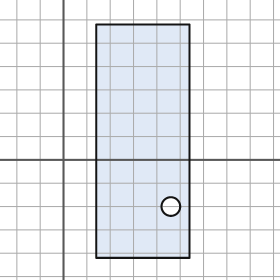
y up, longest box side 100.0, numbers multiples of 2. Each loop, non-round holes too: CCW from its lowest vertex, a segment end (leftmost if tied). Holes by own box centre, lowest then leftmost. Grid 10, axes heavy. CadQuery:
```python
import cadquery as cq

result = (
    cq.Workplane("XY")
    .moveTo(14.0, -42.0)
    .lineTo(54.0, -42.0)
    .lineTo(54.0, 58.0)
    .lineTo(14.0, 58.0)
    .close()
    .moveTo(46.0, -20.0)
    .circle(4.0)
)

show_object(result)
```